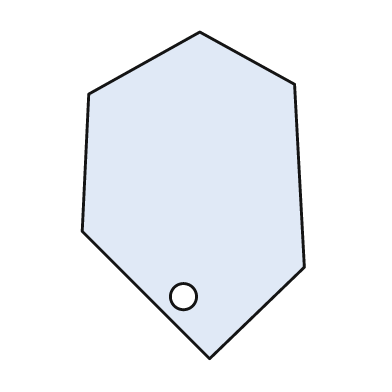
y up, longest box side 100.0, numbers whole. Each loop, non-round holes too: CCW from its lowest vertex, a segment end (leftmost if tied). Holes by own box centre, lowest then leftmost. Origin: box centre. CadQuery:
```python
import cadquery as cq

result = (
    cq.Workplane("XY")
    .moveTo(5.0, -50.0)
    .lineTo(34.0, -22.0)
    .lineTo(31.0, 34.0)
    .lineTo(2.0, 50.0)
    .lineTo(-32.0, 31.0)
    .lineTo(-34.0, -11.0)
    .close()
    .moveTo(-3.0, -31.0)
    .circle(4.0)
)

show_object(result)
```